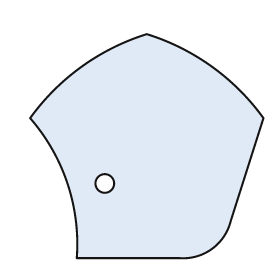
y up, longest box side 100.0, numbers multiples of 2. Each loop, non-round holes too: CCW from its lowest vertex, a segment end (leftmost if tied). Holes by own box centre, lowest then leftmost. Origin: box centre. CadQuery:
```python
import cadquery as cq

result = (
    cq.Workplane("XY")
    .moveTo(-30.0, -48.0)
    .lineTo(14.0, -48.0)
    .threePointArc((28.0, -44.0), (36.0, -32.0))
    .lineTo(50.0, 12.0)
    .threePointArc((28.0, 34.0), (0.0, 48.0))
    .threePointArc((-28.0, 34.0), (-50.0, 12.0))
    .threePointArc((-34.0, -16.0), (-30.0, -48.0))
    .close()
    .moveTo(-18.0, -16.0)
    .circle(4.0)
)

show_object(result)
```